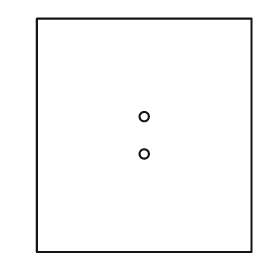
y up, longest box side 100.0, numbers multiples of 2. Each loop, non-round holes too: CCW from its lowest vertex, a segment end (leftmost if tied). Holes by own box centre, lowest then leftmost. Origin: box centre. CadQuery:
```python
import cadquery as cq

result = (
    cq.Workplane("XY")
    .moveTo(-46.0, -50.0)
    .lineTo(46.0, -50.0)
    .lineTo(46.0, 50.0)
    .lineTo(-46.0, 50.0)
    .close()
    .moveTo(0.0, -8.0)
    .circle(2.0)
    .moveTo(0.0, 8.0)
    .circle(2.0)
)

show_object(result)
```